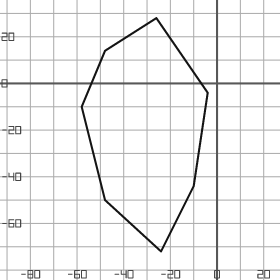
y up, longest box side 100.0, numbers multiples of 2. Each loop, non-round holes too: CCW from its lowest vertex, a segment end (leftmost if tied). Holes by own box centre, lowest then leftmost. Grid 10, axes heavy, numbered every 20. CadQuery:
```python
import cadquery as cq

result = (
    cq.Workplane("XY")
    .moveTo(-24.0, -72.0)
    .lineTo(-10.0, -44.0)
    .lineTo(-4.0, -4.0)
    .lineTo(-26.0, 28.0)
    .lineTo(-48.0, 14.0)
    .lineTo(-58.0, -10.0)
    .lineTo(-48.0, -50.0)
    .close()
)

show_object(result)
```